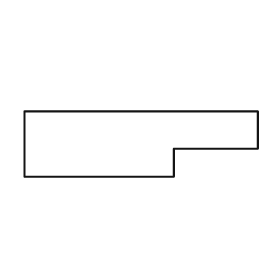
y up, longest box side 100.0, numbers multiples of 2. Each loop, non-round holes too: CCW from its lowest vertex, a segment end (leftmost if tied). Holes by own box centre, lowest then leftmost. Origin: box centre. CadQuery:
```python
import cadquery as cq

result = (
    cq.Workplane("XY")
    .moveTo(-50.0, -14.0)
    .lineTo(14.0, -14.0)
    .lineTo(14.0, -2.0)
    .lineTo(50.0, -2.0)
    .lineTo(50.0, 14.0)
    .lineTo(-50.0, 14.0)
    .close()
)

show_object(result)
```